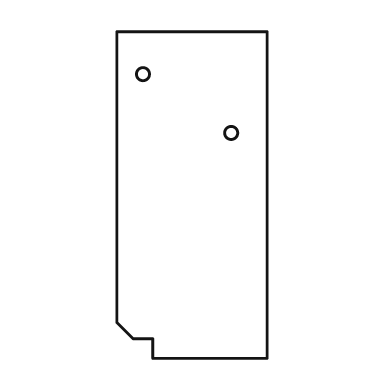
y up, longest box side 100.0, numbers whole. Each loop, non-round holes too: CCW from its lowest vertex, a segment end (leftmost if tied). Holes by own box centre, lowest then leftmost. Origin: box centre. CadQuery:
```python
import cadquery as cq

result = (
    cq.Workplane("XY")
    .moveTo(-12.0, -50.0)
    .lineTo(23.0, -50.0)
    .lineTo(23.0, 50.0)
    .lineTo(-23.0, 50.0)
    .lineTo(-23.0, -39.0)
    .lineTo(-18.0, -44.0)
    .lineTo(-12.0, -44.0)
    .close()
    .moveTo(12.0, 19.0)
    .circle(2.0)
    .moveTo(-15.0, 37.0)
    .circle(2.0)
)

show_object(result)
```